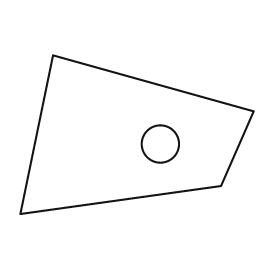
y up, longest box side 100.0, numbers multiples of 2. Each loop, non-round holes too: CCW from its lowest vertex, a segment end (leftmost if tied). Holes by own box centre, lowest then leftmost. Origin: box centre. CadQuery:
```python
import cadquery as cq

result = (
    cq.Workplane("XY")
    .moveTo(-50.0, -34.0)
    .lineTo(36.0, -22.0)
    .lineTo(50.0, 10.0)
    .lineTo(-36.0, 34.0)
    .close()
    .moveTo(10.0, -4.0)
    .circle(8.0)
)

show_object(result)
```